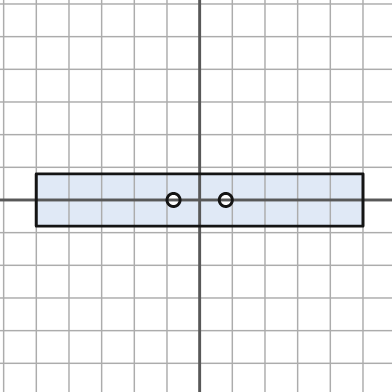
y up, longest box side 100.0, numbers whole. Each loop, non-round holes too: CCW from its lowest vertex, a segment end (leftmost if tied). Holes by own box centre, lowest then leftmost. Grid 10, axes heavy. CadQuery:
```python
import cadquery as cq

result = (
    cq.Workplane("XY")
    .moveTo(-50.0, -8.0)
    .lineTo(50.0, -8.0)
    .lineTo(50.0, 8.0)
    .lineTo(-50.0, 8.0)
    .close()
    .moveTo(-8.0, 0.0)
    .circle(2.0)
    .moveTo(8.0, 0.0)
    .circle(2.0)
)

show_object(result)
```